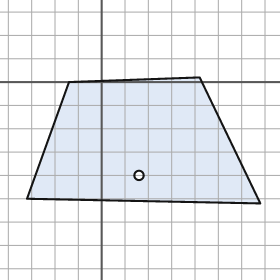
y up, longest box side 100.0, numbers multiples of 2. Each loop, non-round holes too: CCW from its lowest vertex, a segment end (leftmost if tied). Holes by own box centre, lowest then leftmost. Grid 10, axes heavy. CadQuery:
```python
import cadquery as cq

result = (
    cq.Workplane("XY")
    .moveTo(68.0, -52.0)
    .lineTo(42.0, 2.0)
    .lineTo(-14.0, 0.0)
    .lineTo(-32.0, -50.0)
    .close()
    .moveTo(16.0, -40.0)
    .circle(2.0)
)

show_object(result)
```